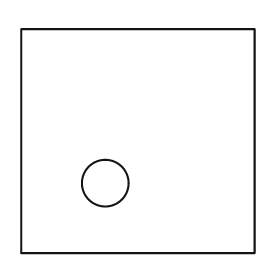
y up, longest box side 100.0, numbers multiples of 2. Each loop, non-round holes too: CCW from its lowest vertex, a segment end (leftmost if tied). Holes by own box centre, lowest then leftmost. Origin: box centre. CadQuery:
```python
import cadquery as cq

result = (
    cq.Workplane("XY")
    .moveTo(-50.0, -48.0)
    .lineTo(50.0, -48.0)
    .lineTo(50.0, 48.0)
    .lineTo(-50.0, 48.0)
    .close()
    .moveTo(-14.0, -18.0)
    .circle(10.0)
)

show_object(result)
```